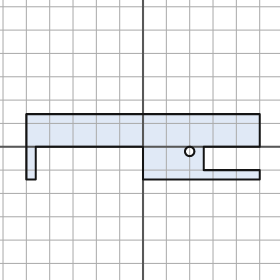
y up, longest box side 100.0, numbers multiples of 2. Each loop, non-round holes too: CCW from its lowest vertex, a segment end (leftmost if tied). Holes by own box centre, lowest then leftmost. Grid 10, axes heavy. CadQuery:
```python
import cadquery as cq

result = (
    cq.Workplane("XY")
    .moveTo(-50.0, -14.0)
    .lineTo(-46.0, -14.0)
    .lineTo(-46.0, 0.0)
    .lineTo(0.0, 0.0)
    .lineTo(0.0, -14.0)
    .lineTo(50.0, -14.0)
    .lineTo(50.0, -10.0)
    .lineTo(26.0, -10.0)
    .lineTo(26.0, 0.0)
    .lineTo(50.0, 0.0)
    .lineTo(50.0, 14.0)
    .lineTo(-50.0, 14.0)
    .close()
    .moveTo(20.0, -2.0)
    .circle(2.0)
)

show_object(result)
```